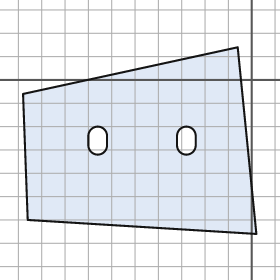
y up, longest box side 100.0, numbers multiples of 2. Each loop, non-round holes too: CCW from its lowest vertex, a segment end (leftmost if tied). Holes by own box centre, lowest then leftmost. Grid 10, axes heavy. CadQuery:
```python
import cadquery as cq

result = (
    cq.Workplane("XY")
    .moveTo(2.0, -66.0)
    .lineTo(-6.0, 14.0)
    .lineTo(-98.0, -6.0)
    .lineTo(-96.0, -60.0)
    .close()
    .moveTo(-70.0, -28.0)
    .threePointArc((-66.0, -32.0), (-62.0, -28.0))
    .lineTo(-62.0, -24.0)
    .threePointArc((-66.0, -20.0), (-70.0, -24.0))
    .close()
    .moveTo(-32.0, -28.0)
    .threePointArc((-28.0, -32.0), (-24.0, -28.0))
    .lineTo(-24.0, -24.0)
    .threePointArc((-28.0, -20.0), (-32.0, -24.0))
    .close()
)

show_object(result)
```